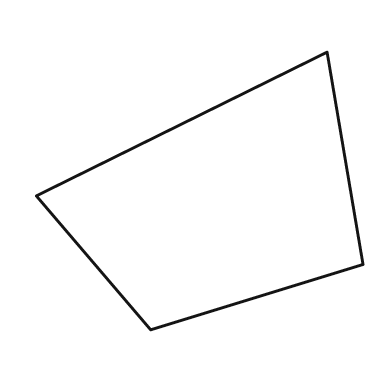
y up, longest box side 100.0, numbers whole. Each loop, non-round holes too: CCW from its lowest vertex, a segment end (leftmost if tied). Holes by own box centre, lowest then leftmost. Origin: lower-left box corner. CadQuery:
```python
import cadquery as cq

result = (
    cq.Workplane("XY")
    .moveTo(35.0, 0.0)
    .lineTo(100.0, 20.0)
    .lineTo(89.0, 85.0)
    .lineTo(0.0, 41.0)
    .close()
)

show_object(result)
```